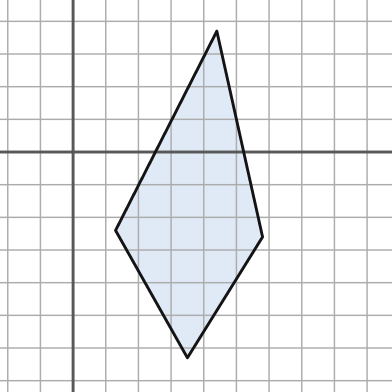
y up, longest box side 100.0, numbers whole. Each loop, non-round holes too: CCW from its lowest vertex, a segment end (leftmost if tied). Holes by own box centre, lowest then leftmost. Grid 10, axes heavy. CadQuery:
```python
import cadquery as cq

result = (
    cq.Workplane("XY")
    .moveTo(35.0, -63.0)
    .lineTo(58.0, -26.0)
    .lineTo(44.0, 37.0)
    .lineTo(13.0, -24.0)
    .close()
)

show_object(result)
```